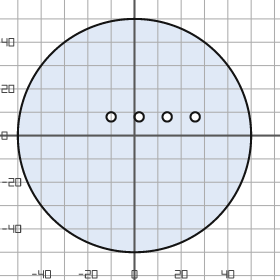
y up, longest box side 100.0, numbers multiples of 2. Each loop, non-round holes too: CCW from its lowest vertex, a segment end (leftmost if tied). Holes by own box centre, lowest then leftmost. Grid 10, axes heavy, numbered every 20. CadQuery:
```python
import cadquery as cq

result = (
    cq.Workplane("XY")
    .moveTo(0.0, 0.0)
    .circle(50.0)
    .moveTo(-10.0, 8.0)
    .circle(2.0)
    .moveTo(2.0, 8.0)
    .circle(2.0)
    .moveTo(14.0, 8.0)
    .circle(2.0)
    .moveTo(26.0, 8.0)
    .circle(2.0)
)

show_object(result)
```